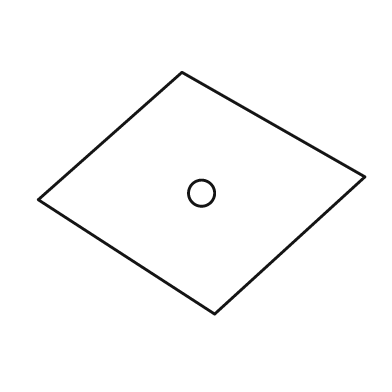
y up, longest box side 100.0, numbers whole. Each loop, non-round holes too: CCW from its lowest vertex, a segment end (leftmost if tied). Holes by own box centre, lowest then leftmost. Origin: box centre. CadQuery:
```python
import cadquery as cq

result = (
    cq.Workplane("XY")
    .moveTo(4.0, -37.0)
    .lineTo(50.0, 5.0)
    .lineTo(-6.0, 37.0)
    .lineTo(-50.0, -2.0)
    .close()
    .moveTo(0.0, 0.0)
    .circle(4.0)
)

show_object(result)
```